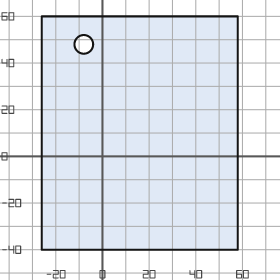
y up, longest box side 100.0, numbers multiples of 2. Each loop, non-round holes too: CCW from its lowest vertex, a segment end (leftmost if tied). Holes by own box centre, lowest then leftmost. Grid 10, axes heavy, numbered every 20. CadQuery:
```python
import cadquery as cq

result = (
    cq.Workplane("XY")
    .moveTo(-26.0, -40.0)
    .lineTo(58.0, -40.0)
    .lineTo(58.0, 60.0)
    .lineTo(-26.0, 60.0)
    .close()
    .moveTo(-8.0, 48.0)
    .circle(4.0)
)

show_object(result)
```